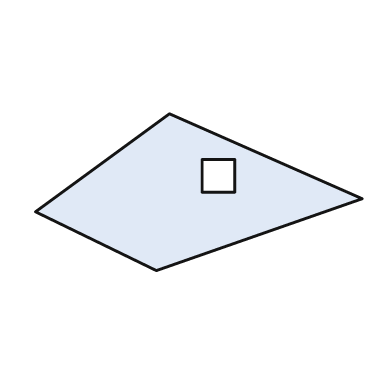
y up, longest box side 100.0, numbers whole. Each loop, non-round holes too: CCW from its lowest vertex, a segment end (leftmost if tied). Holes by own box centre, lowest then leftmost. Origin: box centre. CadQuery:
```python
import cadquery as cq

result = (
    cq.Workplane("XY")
    .moveTo(-13.0, -24.0)
    .lineTo(50.0, -2.0)
    .lineTo(-9.0, 24.0)
    .lineTo(-50.0, -6.0)
    .close()
    .moveTo(1.0, 0.0)
    .lineTo(11.0, 0.0)
    .lineTo(11.0, 10.0)
    .lineTo(1.0, 10.0)
    .close()
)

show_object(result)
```